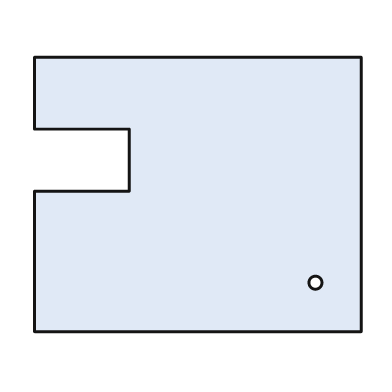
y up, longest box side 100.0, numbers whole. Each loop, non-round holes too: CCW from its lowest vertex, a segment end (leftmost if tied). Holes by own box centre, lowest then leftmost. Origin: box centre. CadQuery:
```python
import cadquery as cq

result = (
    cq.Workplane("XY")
    .moveTo(-50.0, -42.0)
    .lineTo(50.0, -42.0)
    .lineTo(50.0, 42.0)
    .lineTo(-50.0, 42.0)
    .lineTo(-50.0, 20.0)
    .lineTo(-21.0, 20.0)
    .lineTo(-21.0, 1.0)
    .lineTo(-50.0, 1.0)
    .close()
    .moveTo(36.0, -27.0)
    .circle(2.0)
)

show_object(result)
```